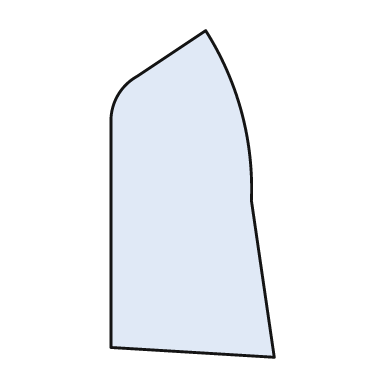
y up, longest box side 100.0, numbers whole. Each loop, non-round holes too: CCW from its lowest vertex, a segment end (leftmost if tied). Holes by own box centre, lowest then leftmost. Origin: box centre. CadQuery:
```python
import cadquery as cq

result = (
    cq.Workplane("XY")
    .moveTo(25.0, -50.0)
    .lineTo(18.0, -2.0)
    .threePointArc((15.0, 25.0), (4.0, 50.0))
    .lineTo(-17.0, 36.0)
    .threePointArc((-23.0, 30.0), (-25.0, 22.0))
    .lineTo(-25.0, -47.0)
    .close()
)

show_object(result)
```